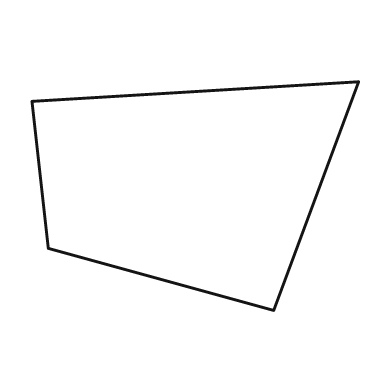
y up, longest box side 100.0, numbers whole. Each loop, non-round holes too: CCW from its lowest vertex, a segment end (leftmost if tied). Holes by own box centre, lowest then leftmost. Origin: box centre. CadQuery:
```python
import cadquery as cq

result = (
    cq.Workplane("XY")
    .moveTo(24.0, -35.0)
    .lineTo(50.0, 35.0)
    .lineTo(-50.0, 29.0)
    .lineTo(-45.0, -16.0)
    .close()
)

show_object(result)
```